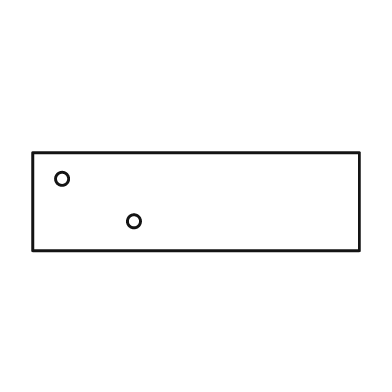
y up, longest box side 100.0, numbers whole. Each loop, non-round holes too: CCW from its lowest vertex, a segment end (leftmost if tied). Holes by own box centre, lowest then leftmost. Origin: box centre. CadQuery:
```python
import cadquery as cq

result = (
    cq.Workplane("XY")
    .moveTo(-50.0, -15.0)
    .lineTo(50.0, -15.0)
    .lineTo(50.0, 15.0)
    .lineTo(-50.0, 15.0)
    .close()
    .moveTo(-19.0, -6.0)
    .circle(2.0)
    .moveTo(-41.0, 7.0)
    .circle(2.0)
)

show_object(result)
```